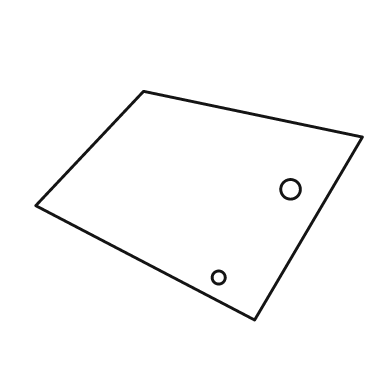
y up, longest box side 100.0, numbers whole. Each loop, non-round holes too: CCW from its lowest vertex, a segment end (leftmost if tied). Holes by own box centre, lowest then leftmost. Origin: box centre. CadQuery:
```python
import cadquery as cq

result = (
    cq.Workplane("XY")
    .moveTo(17.0, -35.0)
    .lineTo(50.0, 21.0)
    .lineTo(-17.0, 35.0)
    .lineTo(-50.0, 0.0)
    .close()
    .moveTo(6.0, -22.0)
    .circle(2.0)
    .moveTo(28.0, 5.0)
    .circle(3.0)
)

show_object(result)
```